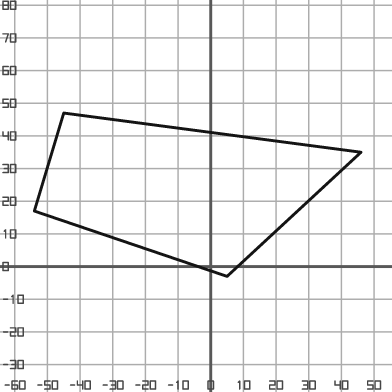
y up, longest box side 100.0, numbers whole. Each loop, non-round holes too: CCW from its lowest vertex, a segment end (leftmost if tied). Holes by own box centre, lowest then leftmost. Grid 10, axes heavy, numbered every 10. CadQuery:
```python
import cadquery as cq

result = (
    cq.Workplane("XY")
    .moveTo(5.0, -3.0)
    .lineTo(46.0, 35.0)
    .lineTo(-45.0, 47.0)
    .lineTo(-54.0, 17.0)
    .close()
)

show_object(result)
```